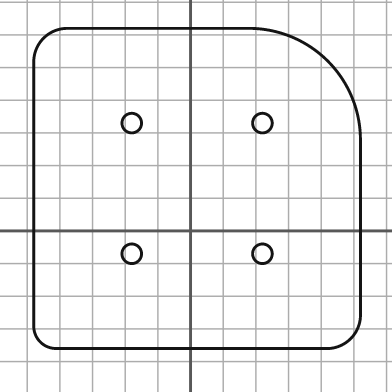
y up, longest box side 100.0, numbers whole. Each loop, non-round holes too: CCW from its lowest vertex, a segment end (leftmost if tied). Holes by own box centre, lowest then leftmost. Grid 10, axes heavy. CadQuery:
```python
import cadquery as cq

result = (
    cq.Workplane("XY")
    .moveTo(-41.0, -36.0)
    .lineTo(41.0, -36.0)
    .threePointArc((49.0, -33.0), (52.0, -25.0))
    .lineTo(52.0, 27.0)
    .threePointArc((42.0, 52.0), (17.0, 62.0))
    .lineTo(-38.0, 62.0)
    .threePointArc((-45.0, 59.0), (-48.0, 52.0))
    .lineTo(-48.0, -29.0)
    .threePointArc((-46.0, -34.0), (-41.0, -36.0))
    .close()
    .moveTo(-18.0, -7.0)
    .circle(3.0)
    .moveTo(22.0, -7.0)
    .circle(3.0)
    .moveTo(-18.0, 33.0)
    .circle(3.0)
    .moveTo(22.0, 33.0)
    .circle(3.0)
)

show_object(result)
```